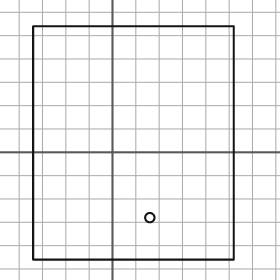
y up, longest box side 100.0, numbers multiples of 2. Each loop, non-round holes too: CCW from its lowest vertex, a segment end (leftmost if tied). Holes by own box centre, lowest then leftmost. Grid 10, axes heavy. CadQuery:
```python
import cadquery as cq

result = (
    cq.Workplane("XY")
    .moveTo(-34.0, -46.0)
    .lineTo(52.0, -46.0)
    .lineTo(52.0, 54.0)
    .lineTo(-34.0, 54.0)
    .close()
    .moveTo(16.0, -28.0)
    .circle(2.0)
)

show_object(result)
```